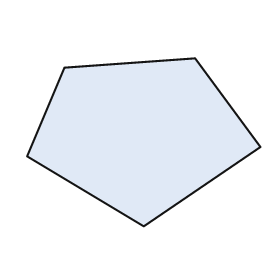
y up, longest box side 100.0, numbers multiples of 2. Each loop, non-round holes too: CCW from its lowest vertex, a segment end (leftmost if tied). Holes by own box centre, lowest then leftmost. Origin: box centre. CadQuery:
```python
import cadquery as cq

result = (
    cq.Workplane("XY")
    .moveTo(0.0, -36.0)
    .lineTo(50.0, -2.0)
    .lineTo(22.0, 36.0)
    .lineTo(-34.0, 32.0)
    .lineTo(-50.0, -6.0)
    .close()
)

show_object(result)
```